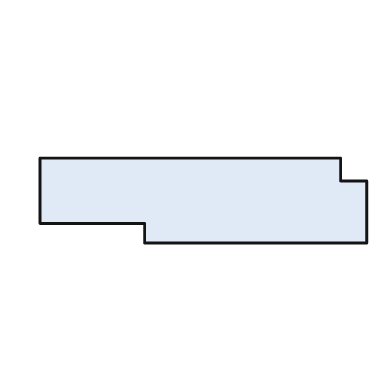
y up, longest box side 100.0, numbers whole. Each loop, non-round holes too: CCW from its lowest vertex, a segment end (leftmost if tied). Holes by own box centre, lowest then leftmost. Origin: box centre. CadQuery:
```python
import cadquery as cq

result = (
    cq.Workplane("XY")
    .moveTo(-18.0, -13.0)
    .lineTo(50.0, -13.0)
    .lineTo(50.0, 6.0)
    .lineTo(42.0, 6.0)
    .lineTo(42.0, 13.0)
    .lineTo(-50.0, 13.0)
    .lineTo(-50.0, -7.0)
    .lineTo(-18.0, -7.0)
    .close()
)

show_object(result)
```